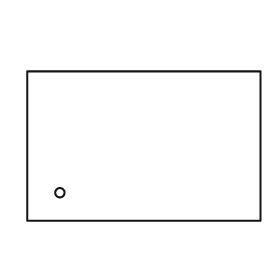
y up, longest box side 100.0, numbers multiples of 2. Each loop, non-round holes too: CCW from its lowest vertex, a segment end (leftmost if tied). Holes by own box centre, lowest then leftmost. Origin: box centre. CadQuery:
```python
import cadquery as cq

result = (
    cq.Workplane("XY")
    .moveTo(-50.0, -32.0)
    .lineTo(50.0, -32.0)
    .lineTo(50.0, 32.0)
    .lineTo(-50.0, 32.0)
    .close()
    .moveTo(-36.0, -20.0)
    .circle(2.0)
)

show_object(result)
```